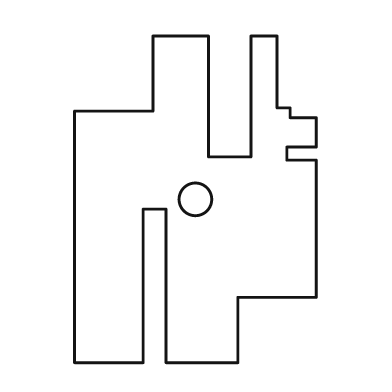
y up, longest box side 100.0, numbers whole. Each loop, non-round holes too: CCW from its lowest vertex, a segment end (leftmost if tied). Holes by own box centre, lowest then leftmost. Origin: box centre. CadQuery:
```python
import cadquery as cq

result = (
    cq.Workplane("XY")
    .moveTo(-37.0, -50.0)
    .lineTo(-16.0, -50.0)
    .lineTo(-16.0, -3.0)
    .lineTo(-9.0, -3.0)
    .lineTo(-9.0, -50.0)
    .lineTo(13.0, -50.0)
    .lineTo(13.0, -30.0)
    .lineTo(37.0, -30.0)
    .lineTo(37.0, 12.0)
    .lineTo(28.0, 12.0)
    .lineTo(28.0, 16.0)
    .lineTo(37.0, 16.0)
    .lineTo(37.0, 25.0)
    .lineTo(29.0, 25.0)
    .lineTo(29.0, 28.0)
    .lineTo(25.0, 28.0)
    .lineTo(25.0, 50.0)
    .lineTo(17.0, 50.0)
    .lineTo(17.0, 13.0)
    .lineTo(4.0, 13.0)
    .lineTo(4.0, 50.0)
    .lineTo(-13.0, 50.0)
    .lineTo(-13.0, 27.0)
    .lineTo(-37.0, 27.0)
    .close()
    .moveTo(0.0, 0.0)
    .circle(5.0)
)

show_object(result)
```